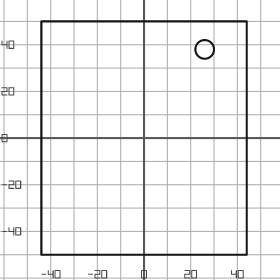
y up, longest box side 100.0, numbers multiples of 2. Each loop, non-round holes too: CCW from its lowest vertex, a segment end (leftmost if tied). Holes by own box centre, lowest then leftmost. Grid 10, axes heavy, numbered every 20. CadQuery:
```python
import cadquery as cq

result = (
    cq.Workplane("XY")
    .moveTo(-44.0, -50.0)
    .lineTo(44.0, -50.0)
    .lineTo(44.0, 50.0)
    .lineTo(-44.0, 50.0)
    .close()
    .moveTo(26.0, 38.0)
    .circle(4.0)
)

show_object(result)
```